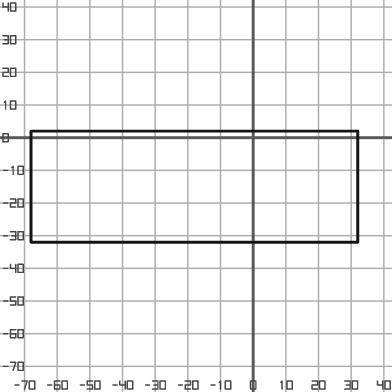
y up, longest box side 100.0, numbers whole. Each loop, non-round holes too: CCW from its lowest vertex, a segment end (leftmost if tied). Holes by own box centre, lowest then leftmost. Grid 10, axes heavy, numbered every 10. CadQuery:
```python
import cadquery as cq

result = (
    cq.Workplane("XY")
    .moveTo(-68.0, -32.0)
    .lineTo(32.0, -32.0)
    .lineTo(32.0, 2.0)
    .lineTo(-68.0, 2.0)
    .close()
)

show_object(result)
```